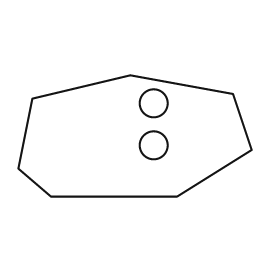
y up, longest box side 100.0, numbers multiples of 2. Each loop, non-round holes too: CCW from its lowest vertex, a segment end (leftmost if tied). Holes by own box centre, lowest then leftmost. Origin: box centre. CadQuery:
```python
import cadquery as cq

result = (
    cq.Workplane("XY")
    .moveTo(-36.0, -26.0)
    .lineTo(18.0, -26.0)
    .lineTo(50.0, -6.0)
    .lineTo(42.0, 18.0)
    .lineTo(-2.0, 26.0)
    .lineTo(-44.0, 16.0)
    .lineTo(-50.0, -14.0)
    .close()
    .moveTo(8.0, -4.0)
    .circle(6.0)
    .moveTo(8.0, 14.0)
    .circle(6.0)
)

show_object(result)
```